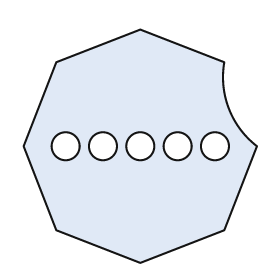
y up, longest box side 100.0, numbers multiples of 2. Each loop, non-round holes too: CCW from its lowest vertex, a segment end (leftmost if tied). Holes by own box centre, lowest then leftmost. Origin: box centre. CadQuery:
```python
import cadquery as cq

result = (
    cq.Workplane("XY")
    .moveTo(0.0, -50.0)
    .lineTo(36.0, -36.0)
    .lineTo(50.0, 0.0)
    .threePointArc((38.0, 16.0), (36.0, 36.0))
    .lineTo(0.0, 50.0)
    .lineTo(-36.0, 36.0)
    .lineTo(-50.0, 0.0)
    .lineTo(-36.0, -36.0)
    .close()
    .moveTo(-32.0, 0.0)
    .circle(6.0)
    .moveTo(-16.0, 0.0)
    .circle(6.0)
    .moveTo(0.0, 0.0)
    .circle(6.0)
    .moveTo(16.0, 0.0)
    .circle(6.0)
    .moveTo(32.0, 0.0)
    .circle(6.0)
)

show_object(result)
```